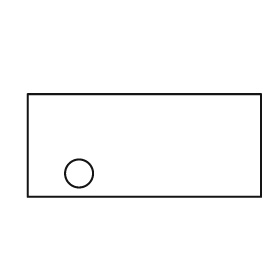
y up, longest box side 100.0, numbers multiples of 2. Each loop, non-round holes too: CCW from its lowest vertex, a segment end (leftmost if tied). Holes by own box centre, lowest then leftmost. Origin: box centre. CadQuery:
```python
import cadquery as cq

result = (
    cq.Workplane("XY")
    .moveTo(-50.0, -22.0)
    .lineTo(50.0, -22.0)
    .lineTo(50.0, 22.0)
    .lineTo(-50.0, 22.0)
    .close()
    .moveTo(-28.0, -12.0)
    .circle(6.0)
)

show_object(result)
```